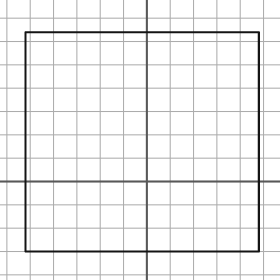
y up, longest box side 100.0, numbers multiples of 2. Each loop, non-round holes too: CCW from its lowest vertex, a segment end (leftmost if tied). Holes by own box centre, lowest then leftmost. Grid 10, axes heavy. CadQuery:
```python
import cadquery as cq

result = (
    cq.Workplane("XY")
    .moveTo(-52.0, -30.0)
    .lineTo(48.0, -30.0)
    .lineTo(48.0, 64.0)
    .lineTo(-52.0, 64.0)
    .close()
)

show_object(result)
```